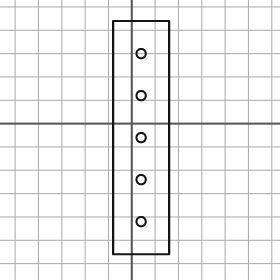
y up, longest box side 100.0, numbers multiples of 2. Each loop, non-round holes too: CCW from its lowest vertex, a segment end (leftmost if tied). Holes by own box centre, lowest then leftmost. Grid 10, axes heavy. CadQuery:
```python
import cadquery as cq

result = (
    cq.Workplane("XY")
    .moveTo(-8.0, -56.0)
    .lineTo(16.0, -56.0)
    .lineTo(16.0, 44.0)
    .lineTo(-8.0, 44.0)
    .close()
    .moveTo(4.0, -42.0)
    .circle(2.0)
    .moveTo(4.0, -24.0)
    .circle(2.0)
    .moveTo(4.0, -6.0)
    .circle(2.0)
    .moveTo(4.0, 12.0)
    .circle(2.0)
    .moveTo(4.0, 30.0)
    .circle(2.0)
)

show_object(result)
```